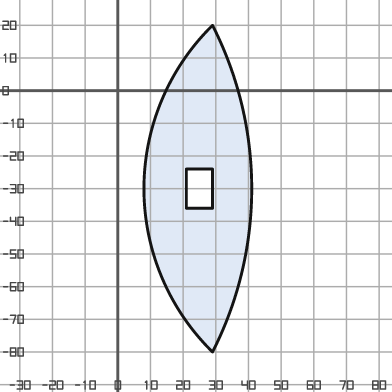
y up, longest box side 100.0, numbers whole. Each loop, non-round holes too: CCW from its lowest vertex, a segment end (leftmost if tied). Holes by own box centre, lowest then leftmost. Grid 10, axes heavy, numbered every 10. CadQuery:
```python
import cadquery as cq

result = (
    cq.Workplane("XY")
    .moveTo(29.0, -80.0)
    .threePointArc((41.0, -30.0), (29.0, 20.0))
    .threePointArc((8.0, -30.0), (29.0, -80.0))
    .close()
    .moveTo(21.0, -36.0)
    .lineTo(29.0, -36.0)
    .lineTo(29.0, -24.0)
    .lineTo(21.0, -24.0)
    .close()
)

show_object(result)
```